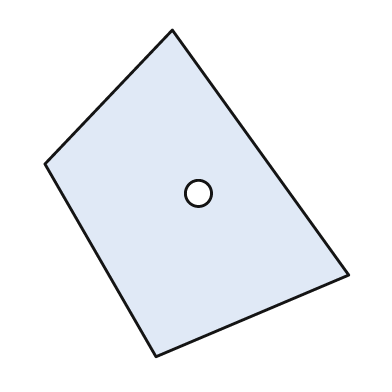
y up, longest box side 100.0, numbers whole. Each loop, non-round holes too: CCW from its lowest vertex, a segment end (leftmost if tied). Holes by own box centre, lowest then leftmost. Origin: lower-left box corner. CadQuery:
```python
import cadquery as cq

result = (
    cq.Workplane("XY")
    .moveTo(34.0, 0.0)
    .lineTo(93.0, 25.0)
    .lineTo(39.0, 100.0)
    .lineTo(0.0, 59.0)
    .close()
    .moveTo(47.0, 50.0)
    .circle(4.0)
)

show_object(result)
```